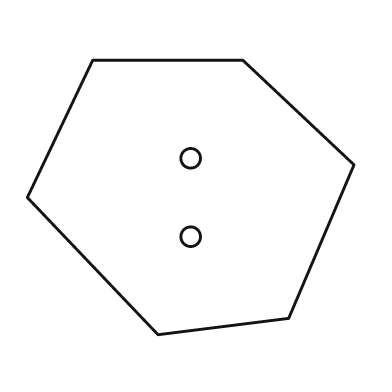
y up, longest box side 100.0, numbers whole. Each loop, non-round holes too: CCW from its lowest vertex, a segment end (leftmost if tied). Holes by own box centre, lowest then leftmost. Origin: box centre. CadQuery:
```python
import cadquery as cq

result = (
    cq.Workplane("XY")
    .moveTo(-10.0, -42.0)
    .lineTo(30.0, -37.0)
    .lineTo(50.0, 10.0)
    .lineTo(16.0, 42.0)
    .lineTo(-30.0, 42.0)
    .lineTo(-50.0, 0.0)
    .close()
    .moveTo(0.0, -12.0)
    .circle(3.0)
    .moveTo(0.0, 12.0)
    .circle(3.0)
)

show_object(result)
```